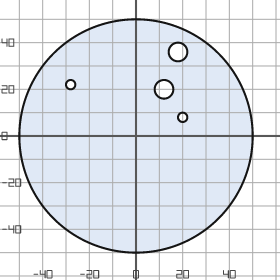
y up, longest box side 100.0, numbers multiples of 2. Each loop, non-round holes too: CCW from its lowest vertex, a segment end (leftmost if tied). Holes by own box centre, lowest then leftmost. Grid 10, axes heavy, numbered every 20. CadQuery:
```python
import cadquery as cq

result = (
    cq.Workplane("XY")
    .moveTo(0.0, 0.0)
    .circle(50.0)
    .moveTo(20.0, 8.0)
    .circle(2.0)
    .moveTo(12.0, 20.0)
    .circle(4.0)
    .moveTo(-28.0, 22.0)
    .circle(2.0)
    .moveTo(18.0, 36.0)
    .circle(4.0)
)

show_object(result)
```